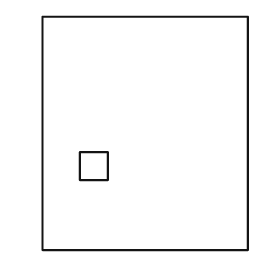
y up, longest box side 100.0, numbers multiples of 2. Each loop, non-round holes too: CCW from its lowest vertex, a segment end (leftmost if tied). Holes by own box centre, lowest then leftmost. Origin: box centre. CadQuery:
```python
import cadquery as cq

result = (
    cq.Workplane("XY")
    .moveTo(-44.0, -50.0)
    .lineTo(44.0, -50.0)
    .lineTo(44.0, 50.0)
    .lineTo(-44.0, 50.0)
    .close()
    .moveTo(-28.0, -20.0)
    .lineTo(-16.0, -20.0)
    .lineTo(-16.0, -8.0)
    .lineTo(-28.0, -8.0)
    .close()
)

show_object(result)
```